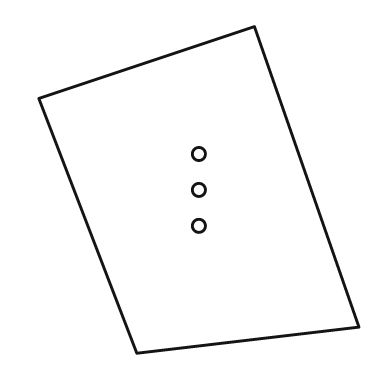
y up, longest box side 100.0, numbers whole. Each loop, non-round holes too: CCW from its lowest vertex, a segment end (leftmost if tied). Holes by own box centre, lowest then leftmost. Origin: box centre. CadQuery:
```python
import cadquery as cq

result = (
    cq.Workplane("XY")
    .moveTo(-19.0, -50.0)
    .lineTo(49.0, -42.0)
    .lineTo(17.0, 50.0)
    .lineTo(-49.0, 28.0)
    .close()
    .moveTo(0.0, -11.0)
    .circle(2.0)
    .moveTo(0.0, 0.0)
    .circle(2.0)
    .moveTo(0.0, 11.0)
    .circle(2.0)
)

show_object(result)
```